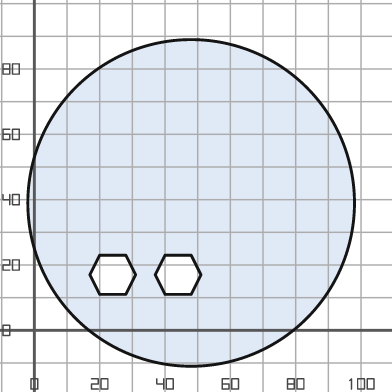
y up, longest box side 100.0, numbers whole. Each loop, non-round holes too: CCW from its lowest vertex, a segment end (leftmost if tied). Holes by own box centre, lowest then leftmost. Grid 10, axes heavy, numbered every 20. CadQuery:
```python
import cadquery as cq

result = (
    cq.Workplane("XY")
    .moveTo(48.0, 39.0)
    .circle(50.0)
    .moveTo(20.0, 11.0)
    .lineTo(28.0, 11.0)
    .lineTo(31.0, 17.0)
    .lineTo(28.0, 23.0)
    .lineTo(20.0, 23.0)
    .lineTo(17.0, 17.0)
    .close()
    .moveTo(40.0, 11.0)
    .lineTo(48.0, 11.0)
    .lineTo(51.0, 17.0)
    .lineTo(48.0, 23.0)
    .lineTo(40.0, 23.0)
    .lineTo(37.0, 17.0)
    .close()
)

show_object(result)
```